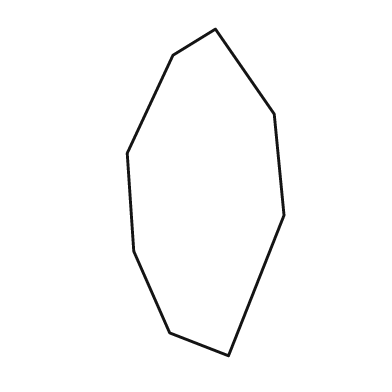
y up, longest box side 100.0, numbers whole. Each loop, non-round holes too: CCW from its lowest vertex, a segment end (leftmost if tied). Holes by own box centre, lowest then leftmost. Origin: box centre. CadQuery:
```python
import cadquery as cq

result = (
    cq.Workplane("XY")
    .moveTo(7.0, -50.0)
    .lineTo(24.0, -7.0)
    .lineTo(21.0, 24.0)
    .lineTo(3.0, 50.0)
    .lineTo(-10.0, 42.0)
    .lineTo(-24.0, 12.0)
    .lineTo(-22.0, -18.0)
    .lineTo(-11.0, -43.0)
    .close()
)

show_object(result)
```